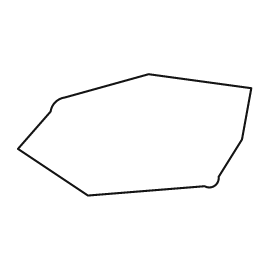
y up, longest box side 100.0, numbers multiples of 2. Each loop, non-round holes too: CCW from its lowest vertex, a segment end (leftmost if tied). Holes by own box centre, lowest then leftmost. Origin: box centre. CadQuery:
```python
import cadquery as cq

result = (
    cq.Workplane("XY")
    .moveTo(-20.0, -26.0)
    .lineTo(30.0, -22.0)
    .threePointArc((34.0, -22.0), (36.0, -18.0))
    .lineTo(46.0, -2.0)
    .lineTo(50.0, 20.0)
    .lineTo(6.0, 26.0)
    .lineTo(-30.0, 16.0)
    .threePointArc((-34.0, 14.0), (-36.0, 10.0))
    .lineTo(-50.0, -6.0)
    .close()
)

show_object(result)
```